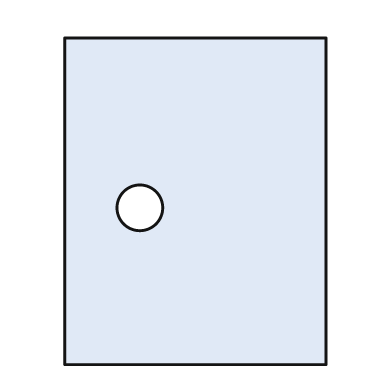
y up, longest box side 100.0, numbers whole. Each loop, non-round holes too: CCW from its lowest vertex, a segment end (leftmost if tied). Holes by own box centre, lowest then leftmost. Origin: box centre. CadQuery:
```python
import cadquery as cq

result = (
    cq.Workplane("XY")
    .moveTo(-40.0, -50.0)
    .lineTo(40.0, -50.0)
    .lineTo(40.0, 50.0)
    .lineTo(-40.0, 50.0)
    .close()
    .moveTo(-17.0, -2.0)
    .circle(7.0)
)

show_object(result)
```